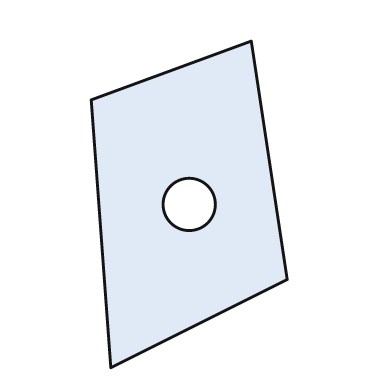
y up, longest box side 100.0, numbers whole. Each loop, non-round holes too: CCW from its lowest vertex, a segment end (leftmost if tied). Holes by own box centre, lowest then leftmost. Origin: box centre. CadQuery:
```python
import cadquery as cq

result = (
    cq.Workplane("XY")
    .moveTo(-24.0, -50.0)
    .lineTo(30.0, -23.0)
    .lineTo(19.0, 50.0)
    .lineTo(-30.0, 32.0)
    .close()
    .moveTo(0.0, 0.0)
    .circle(8.0)
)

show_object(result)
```